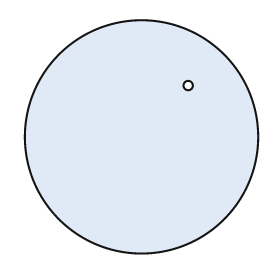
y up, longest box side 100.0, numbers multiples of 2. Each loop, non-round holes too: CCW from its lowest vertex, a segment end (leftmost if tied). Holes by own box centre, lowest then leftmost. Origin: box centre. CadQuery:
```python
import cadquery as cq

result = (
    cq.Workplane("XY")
    .moveTo(0.0, 0.0)
    .circle(50.0)
    .moveTo(20.0, 22.0)
    .circle(2.0)
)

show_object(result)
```